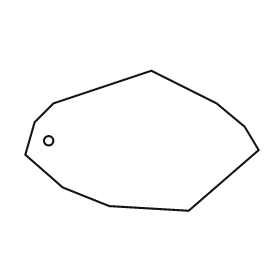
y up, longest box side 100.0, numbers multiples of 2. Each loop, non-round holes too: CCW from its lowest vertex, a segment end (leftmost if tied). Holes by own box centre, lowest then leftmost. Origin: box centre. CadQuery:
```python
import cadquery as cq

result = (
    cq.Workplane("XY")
    .moveTo(20.0, -30.0)
    .lineTo(50.0, -4.0)
    .lineTo(44.0, 6.0)
    .lineTo(32.0, 16.0)
    .lineTo(4.0, 30.0)
    .lineTo(-38.0, 16.0)
    .lineTo(-46.0, 8.0)
    .lineTo(-50.0, -6.0)
    .lineTo(-34.0, -20.0)
    .lineTo(-14.0, -28.0)
    .close()
    .moveTo(-40.0, 0.0)
    .circle(2.0)
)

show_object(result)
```